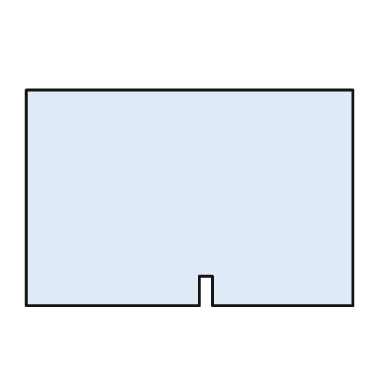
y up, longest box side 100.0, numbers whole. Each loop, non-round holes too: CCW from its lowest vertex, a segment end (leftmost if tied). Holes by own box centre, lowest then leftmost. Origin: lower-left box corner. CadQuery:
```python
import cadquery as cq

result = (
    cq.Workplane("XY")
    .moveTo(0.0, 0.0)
    .lineTo(53.0, 0.0)
    .lineTo(53.0, 9.0)
    .lineTo(57.0, 9.0)
    .lineTo(57.0, 0.0)
    .lineTo(100.0, 0.0)
    .lineTo(100.0, 66.0)
    .lineTo(0.0, 66.0)
    .close()
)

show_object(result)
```